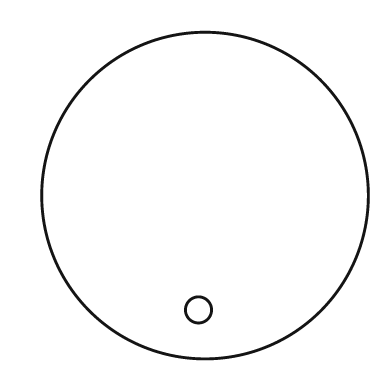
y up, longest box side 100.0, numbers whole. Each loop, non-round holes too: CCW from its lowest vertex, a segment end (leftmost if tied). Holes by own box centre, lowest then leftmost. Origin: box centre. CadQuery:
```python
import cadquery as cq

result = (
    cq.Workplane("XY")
    .moveTo(0.0, 0.0)
    .circle(50.0)
    .moveTo(-2.0, -35.0)
    .circle(4.0)
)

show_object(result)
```